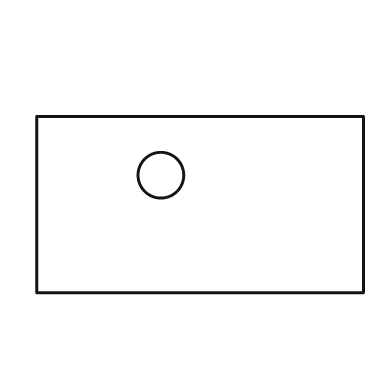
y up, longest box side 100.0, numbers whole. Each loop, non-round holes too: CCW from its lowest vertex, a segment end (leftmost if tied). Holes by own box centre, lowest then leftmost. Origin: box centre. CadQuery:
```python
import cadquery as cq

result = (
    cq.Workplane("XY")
    .moveTo(-50.0, -27.0)
    .lineTo(50.0, -27.0)
    .lineTo(50.0, 27.0)
    .lineTo(-50.0, 27.0)
    .close()
    .moveTo(-12.0, 9.0)
    .circle(7.0)
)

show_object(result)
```